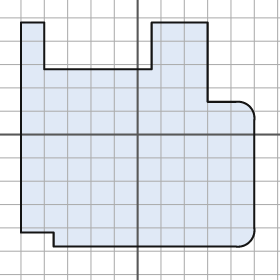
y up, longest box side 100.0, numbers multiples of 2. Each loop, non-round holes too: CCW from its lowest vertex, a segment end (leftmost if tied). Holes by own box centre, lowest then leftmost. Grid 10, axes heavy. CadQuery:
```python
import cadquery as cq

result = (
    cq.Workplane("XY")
    .moveTo(-36.0, -48.0)
    .lineTo(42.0, -48.0)
    .threePointArc((48.0, -46.0), (50.0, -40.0))
    .lineTo(50.0, 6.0)
    .threePointArc((48.0, 12.0), (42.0, 14.0))
    .lineTo(30.0, 14.0)
    .lineTo(30.0, 48.0)
    .lineTo(6.0, 48.0)
    .lineTo(6.0, 28.0)
    .lineTo(-40.0, 28.0)
    .lineTo(-40.0, 48.0)
    .lineTo(-50.0, 48.0)
    .lineTo(-50.0, -42.0)
    .lineTo(-36.0, -42.0)
    .close()
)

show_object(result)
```